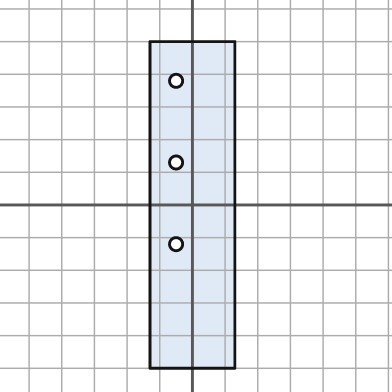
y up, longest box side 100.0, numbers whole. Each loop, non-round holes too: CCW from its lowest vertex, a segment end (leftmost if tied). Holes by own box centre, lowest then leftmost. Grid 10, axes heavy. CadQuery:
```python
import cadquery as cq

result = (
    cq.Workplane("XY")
    .moveTo(-13.0, -50.0)
    .lineTo(13.0, -50.0)
    .lineTo(13.0, 50.0)
    .lineTo(-13.0, 50.0)
    .close()
    .moveTo(-5.0, -12.0)
    .circle(2.0)
    .moveTo(-5.0, 13.0)
    .circle(2.0)
    .moveTo(-5.0, 38.0)
    .circle(2.0)
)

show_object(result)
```